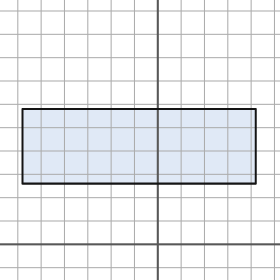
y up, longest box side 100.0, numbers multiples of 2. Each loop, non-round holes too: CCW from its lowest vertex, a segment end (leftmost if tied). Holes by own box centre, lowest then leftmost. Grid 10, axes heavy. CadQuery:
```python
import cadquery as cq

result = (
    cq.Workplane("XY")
    .moveTo(-58.0, 26.0)
    .lineTo(42.0, 26.0)
    .lineTo(42.0, 58.0)
    .lineTo(-58.0, 58.0)
    .close()
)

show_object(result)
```